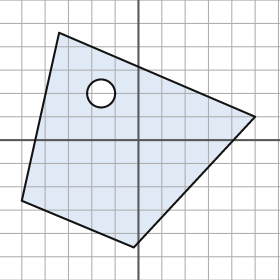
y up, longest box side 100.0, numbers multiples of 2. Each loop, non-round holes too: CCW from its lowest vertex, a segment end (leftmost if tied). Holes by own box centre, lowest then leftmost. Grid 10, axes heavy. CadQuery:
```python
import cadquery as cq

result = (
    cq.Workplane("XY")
    .moveTo(-2.0, -46.0)
    .lineTo(50.0, 10.0)
    .lineTo(-34.0, 46.0)
    .lineTo(-50.0, -26.0)
    .close()
    .moveTo(-16.0, 20.0)
    .circle(6.0)
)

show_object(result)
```